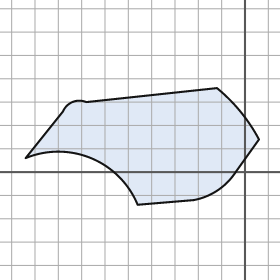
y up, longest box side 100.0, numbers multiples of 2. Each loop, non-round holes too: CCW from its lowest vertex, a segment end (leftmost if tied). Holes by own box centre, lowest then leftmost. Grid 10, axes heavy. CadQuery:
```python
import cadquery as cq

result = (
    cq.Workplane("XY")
    .moveTo(-46.0, -14.0)
    .lineTo(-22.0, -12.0)
    .threePointArc((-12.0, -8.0), (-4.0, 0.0))
    .lineTo(6.0, 14.0)
    .threePointArc((-2.0, 26.0), (-12.0, 36.0))
    .lineTo(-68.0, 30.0)
    .threePointArc((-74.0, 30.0), (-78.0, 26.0))
    .lineTo(-94.0, 6.0)
    .threePointArc((-66.0, 6.0), (-46.0, -14.0))
    .close()
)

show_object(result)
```